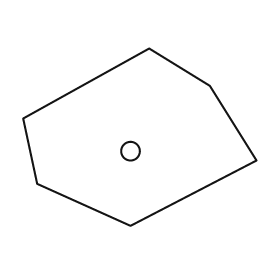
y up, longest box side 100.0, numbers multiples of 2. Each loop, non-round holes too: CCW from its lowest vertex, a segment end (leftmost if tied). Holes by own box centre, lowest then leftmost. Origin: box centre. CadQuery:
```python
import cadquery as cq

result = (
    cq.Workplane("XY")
    .moveTo(-4.0, -38.0)
    .lineTo(50.0, -10.0)
    .lineTo(30.0, 22.0)
    .lineTo(4.0, 38.0)
    .lineTo(-50.0, 8.0)
    .lineTo(-44.0, -20.0)
    .close()
    .moveTo(-4.0, -6.0)
    .circle(4.0)
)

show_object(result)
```